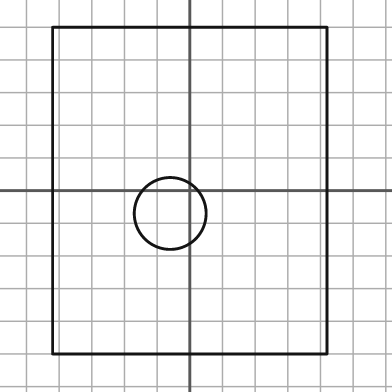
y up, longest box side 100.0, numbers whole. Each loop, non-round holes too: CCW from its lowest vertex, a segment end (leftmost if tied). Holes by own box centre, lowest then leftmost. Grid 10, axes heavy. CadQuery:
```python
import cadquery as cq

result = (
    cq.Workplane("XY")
    .moveTo(-42.0, -50.0)
    .lineTo(42.0, -50.0)
    .lineTo(42.0, 50.0)
    .lineTo(-42.0, 50.0)
    .close()
    .moveTo(-6.0, -7.0)
    .circle(11.0)
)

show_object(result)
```